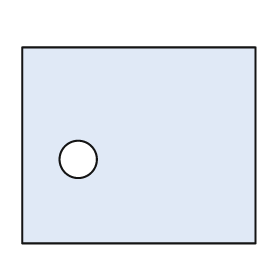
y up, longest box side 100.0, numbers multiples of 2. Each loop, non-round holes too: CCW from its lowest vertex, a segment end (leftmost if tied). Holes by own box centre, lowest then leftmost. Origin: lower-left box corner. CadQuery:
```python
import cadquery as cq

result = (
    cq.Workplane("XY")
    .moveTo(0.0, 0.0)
    .lineTo(100.0, 0.0)
    .lineTo(100.0, 84.0)
    .lineTo(0.0, 84.0)
    .close()
    .moveTo(24.0, 36.0)
    .circle(8.0)
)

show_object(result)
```